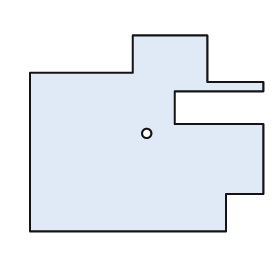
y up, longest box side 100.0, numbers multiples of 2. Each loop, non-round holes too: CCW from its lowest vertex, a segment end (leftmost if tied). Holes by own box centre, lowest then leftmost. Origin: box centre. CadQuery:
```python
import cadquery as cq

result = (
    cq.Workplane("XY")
    .moveTo(-50.0, -42.0)
    .lineTo(34.0, -42.0)
    .lineTo(34.0, -26.0)
    .lineTo(50.0, -26.0)
    .lineTo(50.0, 4.0)
    .lineTo(12.0, 4.0)
    .lineTo(12.0, 18.0)
    .lineTo(50.0, 18.0)
    .lineTo(50.0, 22.0)
    .lineTo(26.0, 22.0)
    .lineTo(26.0, 42.0)
    .lineTo(-6.0, 42.0)
    .lineTo(-6.0, 26.0)
    .lineTo(-50.0, 26.0)
    .close()
    .moveTo(0.0, 0.0)
    .circle(2.0)
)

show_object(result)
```